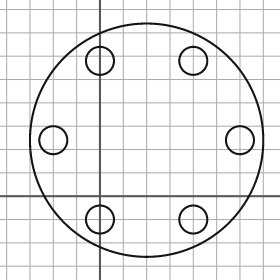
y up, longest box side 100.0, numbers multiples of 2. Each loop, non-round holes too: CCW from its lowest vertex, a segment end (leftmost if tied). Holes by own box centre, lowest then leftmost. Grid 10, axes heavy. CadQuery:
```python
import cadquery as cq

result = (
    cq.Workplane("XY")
    .moveTo(20.0, 24.0)
    .circle(50.0)
    .moveTo(0.0, -10.0)
    .circle(6.0)
    .moveTo(40.0, -10.0)
    .circle(6.0)
    .moveTo(-20.0, 24.0)
    .circle(6.0)
    .moveTo(60.0, 24.0)
    .circle(6.0)
    .moveTo(0.0, 58.0)
    .circle(6.0)
    .moveTo(40.0, 58.0)
    .circle(6.0)
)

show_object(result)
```